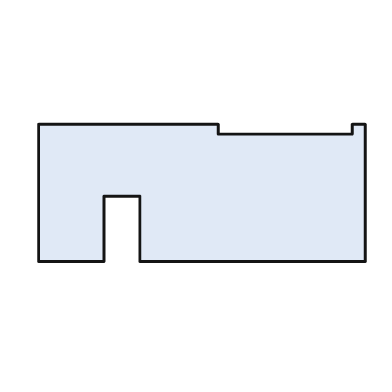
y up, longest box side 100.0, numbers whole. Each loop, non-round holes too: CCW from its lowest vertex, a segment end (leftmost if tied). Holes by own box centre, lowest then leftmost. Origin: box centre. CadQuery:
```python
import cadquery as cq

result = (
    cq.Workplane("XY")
    .moveTo(-50.0, -21.0)
    .lineTo(-30.0, -21.0)
    .lineTo(-30.0, -1.0)
    .lineTo(-19.0, -1.0)
    .lineTo(-19.0, -21.0)
    .lineTo(50.0, -21.0)
    .lineTo(50.0, 21.0)
    .lineTo(46.0, 21.0)
    .lineTo(46.0, 18.0)
    .lineTo(5.0, 18.0)
    .lineTo(5.0, 21.0)
    .lineTo(-50.0, 21.0)
    .close()
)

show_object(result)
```